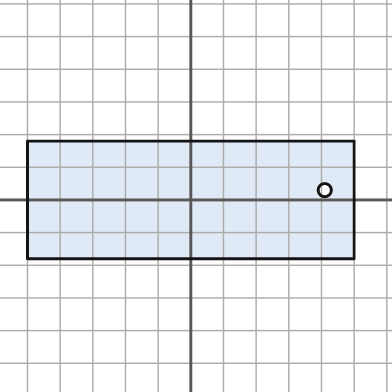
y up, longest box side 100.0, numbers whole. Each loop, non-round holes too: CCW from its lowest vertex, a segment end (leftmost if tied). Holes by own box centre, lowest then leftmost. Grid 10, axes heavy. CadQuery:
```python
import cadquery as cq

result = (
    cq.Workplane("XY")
    .moveTo(-50.0, -18.0)
    .lineTo(50.0, -18.0)
    .lineTo(50.0, 18.0)
    .lineTo(-50.0, 18.0)
    .close()
    .moveTo(41.0, 3.0)
    .circle(2.0)
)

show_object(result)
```